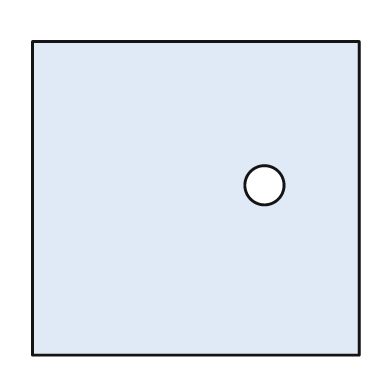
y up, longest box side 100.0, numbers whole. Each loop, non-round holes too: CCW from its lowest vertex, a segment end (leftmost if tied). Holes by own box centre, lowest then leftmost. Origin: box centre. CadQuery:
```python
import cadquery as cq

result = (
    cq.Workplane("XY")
    .moveTo(-50.0, -48.0)
    .lineTo(50.0, -48.0)
    .lineTo(50.0, 48.0)
    .lineTo(-50.0, 48.0)
    .close()
    .moveTo(21.0, 4.0)
    .circle(6.0)
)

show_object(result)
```